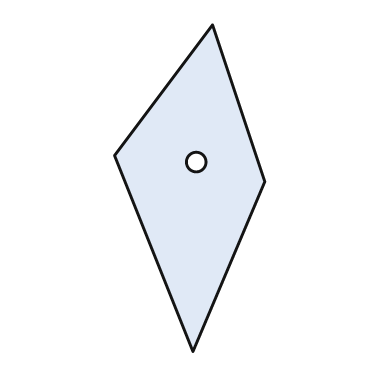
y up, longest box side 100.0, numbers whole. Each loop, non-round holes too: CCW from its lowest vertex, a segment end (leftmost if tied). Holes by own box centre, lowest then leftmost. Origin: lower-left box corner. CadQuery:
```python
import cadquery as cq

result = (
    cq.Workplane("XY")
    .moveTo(24.0, 0.0)
    .lineTo(46.0, 52.0)
    .lineTo(30.0, 100.0)
    .lineTo(0.0, 60.0)
    .close()
    .moveTo(25.0, 58.0)
    .circle(3.0)
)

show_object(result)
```